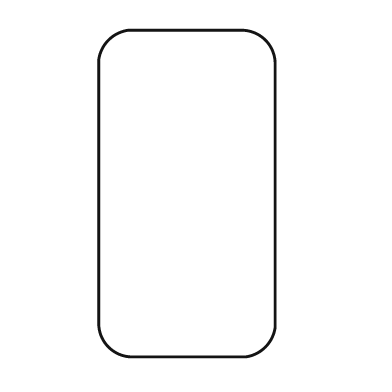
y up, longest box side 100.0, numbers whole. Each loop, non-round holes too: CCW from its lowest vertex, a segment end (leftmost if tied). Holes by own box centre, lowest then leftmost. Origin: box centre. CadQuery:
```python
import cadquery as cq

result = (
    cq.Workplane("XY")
    .moveTo(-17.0, -50.0)
    .lineTo(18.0, -50.0)
    .threePointArc((24.0, -47.0), (27.0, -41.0))
    .lineTo(27.0, 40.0)
    .threePointArc((24.0, 47.0), (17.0, 50.0))
    .lineTo(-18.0, 50.0)
    .threePointArc((-24.0, 47.0), (-27.0, 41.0))
    .lineTo(-27.0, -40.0)
    .threePointArc((-24.0, -47.0), (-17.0, -50.0))
    .close()
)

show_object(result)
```